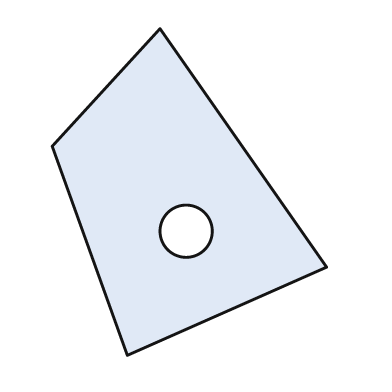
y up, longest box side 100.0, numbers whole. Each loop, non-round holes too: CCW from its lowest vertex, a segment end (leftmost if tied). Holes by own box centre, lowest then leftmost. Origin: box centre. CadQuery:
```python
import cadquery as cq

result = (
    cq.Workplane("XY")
    .moveTo(-19.0, -50.0)
    .lineTo(42.0, -23.0)
    .lineTo(-9.0, 50.0)
    .lineTo(-42.0, 14.0)
    .close()
    .moveTo(-1.0, -12.0)
    .circle(8.0)
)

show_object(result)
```